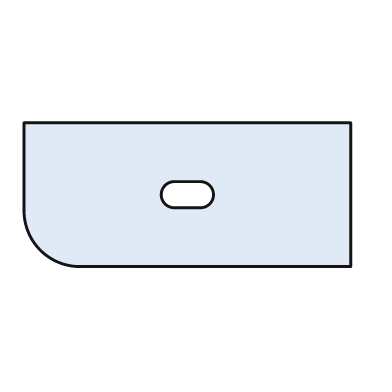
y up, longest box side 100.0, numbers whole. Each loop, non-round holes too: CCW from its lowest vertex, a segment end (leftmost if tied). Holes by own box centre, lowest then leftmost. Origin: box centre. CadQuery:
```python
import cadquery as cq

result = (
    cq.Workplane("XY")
    .moveTo(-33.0, -22.0)
    .lineTo(50.0, -22.0)
    .lineTo(50.0, 22.0)
    .lineTo(-50.0, 22.0)
    .lineTo(-50.0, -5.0)
    .threePointArc((-45.0, -17.0), (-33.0, -22.0))
    .close()
    .moveTo(-4.0, -4.0)
    .lineTo(4.0, -4.0)
    .threePointArc((8.0, 0.0), (4.0, 4.0))
    .lineTo(-4.0, 4.0)
    .threePointArc((-8.0, 0.0), (-4.0, -4.0))
    .close()
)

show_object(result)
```